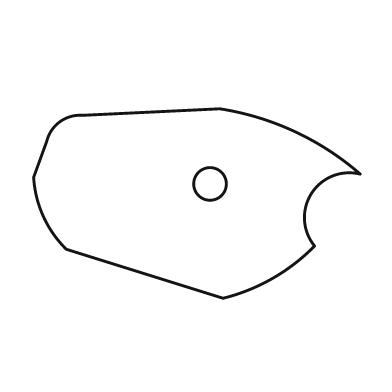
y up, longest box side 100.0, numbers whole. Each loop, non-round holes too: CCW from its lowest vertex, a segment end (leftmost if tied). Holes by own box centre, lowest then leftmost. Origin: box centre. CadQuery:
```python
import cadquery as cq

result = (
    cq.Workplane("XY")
    .moveTo(8.0, -29.0)
    .threePointArc((23.0, -23.0), (36.0, -13.0))
    .threePointArc((35.0, 3.0), (50.0, 9.0))
    .threePointArc((30.0, 22.0), (7.0, 29.0))
    .lineTo(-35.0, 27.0)
    .threePointArc((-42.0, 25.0), (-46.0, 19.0))
    .lineTo(-50.0, 8.0)
    .threePointArc((-47.0, -4.0), (-40.0, -14.0))
    .close()
    .moveTo(4.0, 6.0)
    .circle(5.0)
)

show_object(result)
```